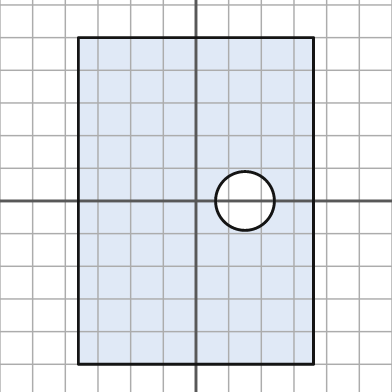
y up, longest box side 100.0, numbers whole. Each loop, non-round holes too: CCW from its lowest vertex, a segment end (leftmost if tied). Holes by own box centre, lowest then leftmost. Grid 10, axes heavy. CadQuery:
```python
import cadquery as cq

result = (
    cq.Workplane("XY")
    .moveTo(-36.0, -50.0)
    .lineTo(36.0, -50.0)
    .lineTo(36.0, 50.0)
    .lineTo(-36.0, 50.0)
    .close()
    .moveTo(15.0, 0.0)
    .circle(9.0)
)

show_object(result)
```